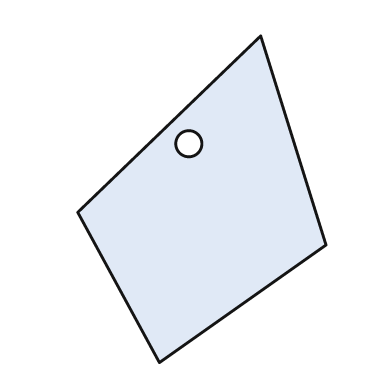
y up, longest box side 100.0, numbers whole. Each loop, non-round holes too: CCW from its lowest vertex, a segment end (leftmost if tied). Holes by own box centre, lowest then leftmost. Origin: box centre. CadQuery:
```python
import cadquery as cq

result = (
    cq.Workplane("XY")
    .moveTo(-13.0, -50.0)
    .lineTo(38.0, -14.0)
    .lineTo(18.0, 50.0)
    .lineTo(-38.0, -4.0)
    .close()
    .moveTo(-4.0, 17.0)
    .circle(4.0)
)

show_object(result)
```